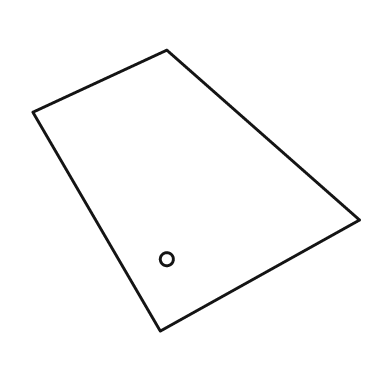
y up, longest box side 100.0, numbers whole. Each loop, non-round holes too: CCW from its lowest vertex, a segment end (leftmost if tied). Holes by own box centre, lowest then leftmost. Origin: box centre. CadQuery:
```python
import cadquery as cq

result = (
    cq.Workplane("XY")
    .moveTo(-11.0, -43.0)
    .lineTo(50.0, -9.0)
    .lineTo(-9.0, 43.0)
    .lineTo(-50.0, 24.0)
    .close()
    .moveTo(-9.0, -21.0)
    .circle(2.0)
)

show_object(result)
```